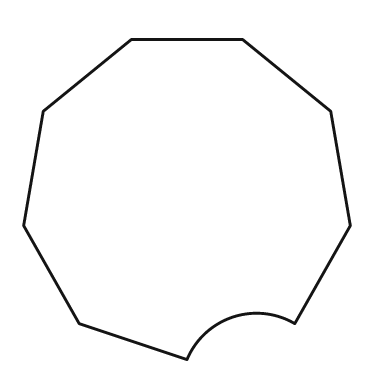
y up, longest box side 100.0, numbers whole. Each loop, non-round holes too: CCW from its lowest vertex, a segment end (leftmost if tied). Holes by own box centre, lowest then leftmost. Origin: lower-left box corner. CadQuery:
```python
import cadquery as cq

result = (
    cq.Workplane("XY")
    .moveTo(50.0, 0.0)
    .threePointArc((64.0, 13.0), (83.0, 11.0))
    .lineTo(100.0, 41.0)
    .lineTo(94.0, 76.0)
    .lineTo(67.0, 98.0)
    .lineTo(33.0, 98.0)
    .lineTo(6.0, 76.0)
    .lineTo(0.0, 41.0)
    .lineTo(17.0, 11.0)
    .close()
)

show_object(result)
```